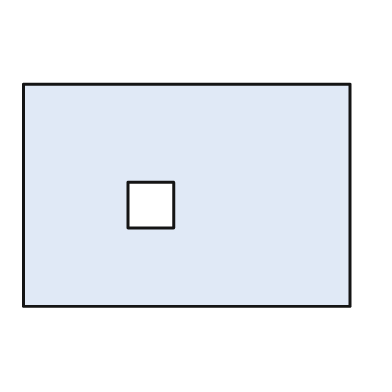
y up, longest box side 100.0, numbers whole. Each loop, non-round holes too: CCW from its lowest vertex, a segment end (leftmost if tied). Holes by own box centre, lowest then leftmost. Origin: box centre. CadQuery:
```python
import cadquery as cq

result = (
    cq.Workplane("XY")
    .moveTo(-50.0, -34.0)
    .lineTo(50.0, -34.0)
    .lineTo(50.0, 34.0)
    .lineTo(-50.0, 34.0)
    .close()
    .moveTo(-18.0, -10.0)
    .lineTo(-4.0, -10.0)
    .lineTo(-4.0, 4.0)
    .lineTo(-18.0, 4.0)
    .close()
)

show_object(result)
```